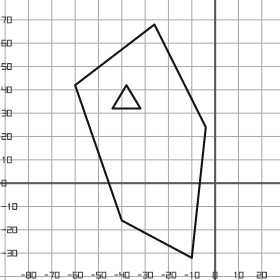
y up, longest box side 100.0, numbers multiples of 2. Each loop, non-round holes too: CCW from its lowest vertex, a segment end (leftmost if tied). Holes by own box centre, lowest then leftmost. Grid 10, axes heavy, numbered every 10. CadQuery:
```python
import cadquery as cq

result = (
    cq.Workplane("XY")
    .moveTo(-10.0, -32.0)
    .lineTo(-4.0, 24.0)
    .lineTo(-26.0, 68.0)
    .lineTo(-60.0, 42.0)
    .lineTo(-40.0, -16.0)
    .close()
    .moveTo(-44.0, 32.0)
    .lineTo(-32.0, 32.0)
    .lineTo(-38.0, 42.0)
    .close()
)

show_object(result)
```